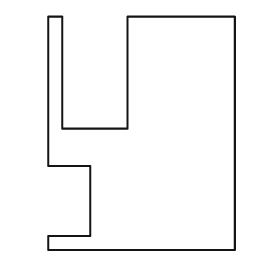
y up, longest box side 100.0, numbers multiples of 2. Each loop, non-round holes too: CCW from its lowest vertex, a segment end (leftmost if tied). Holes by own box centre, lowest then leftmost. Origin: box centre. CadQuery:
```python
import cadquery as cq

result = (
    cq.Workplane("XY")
    .moveTo(-40.0, -50.0)
    .lineTo(40.0, -50.0)
    .lineTo(40.0, 50.0)
    .lineTo(-6.0, 50.0)
    .lineTo(-6.0, 2.0)
    .lineTo(-34.0, 2.0)
    .lineTo(-34.0, 50.0)
    .lineTo(-40.0, 50.0)
    .lineTo(-40.0, -14.0)
    .lineTo(-22.0, -14.0)
    .lineTo(-22.0, -44.0)
    .lineTo(-40.0, -44.0)
    .close()
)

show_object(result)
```